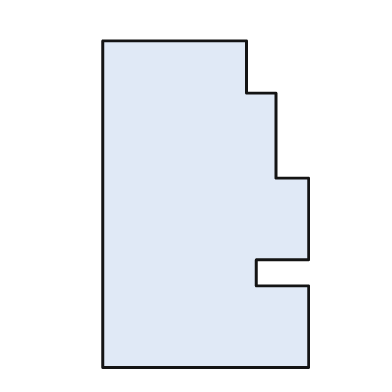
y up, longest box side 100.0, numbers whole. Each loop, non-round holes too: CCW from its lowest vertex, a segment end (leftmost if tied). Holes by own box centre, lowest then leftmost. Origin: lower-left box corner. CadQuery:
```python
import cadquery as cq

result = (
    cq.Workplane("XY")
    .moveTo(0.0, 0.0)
    .lineTo(63.0, 0.0)
    .lineTo(63.0, 25.0)
    .lineTo(47.0, 25.0)
    .lineTo(47.0, 33.0)
    .lineTo(63.0, 33.0)
    .lineTo(63.0, 58.0)
    .lineTo(53.0, 58.0)
    .lineTo(53.0, 84.0)
    .lineTo(44.0, 84.0)
    .lineTo(44.0, 100.0)
    .lineTo(0.0, 100.0)
    .close()
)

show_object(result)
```